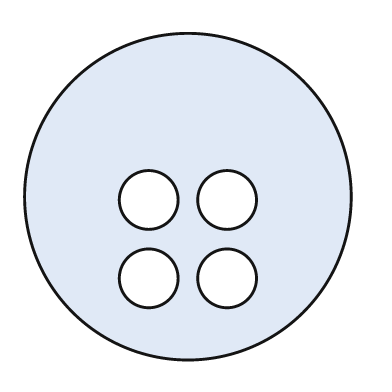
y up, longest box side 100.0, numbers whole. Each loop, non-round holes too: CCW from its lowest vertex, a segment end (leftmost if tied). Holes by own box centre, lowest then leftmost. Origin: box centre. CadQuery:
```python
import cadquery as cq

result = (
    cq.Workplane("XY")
    .moveTo(0.0, 0.0)
    .circle(50.0)
    .moveTo(-12.0, -25.0)
    .circle(9.0)
    .moveTo(12.0, -25.0)
    .circle(9.0)
    .moveTo(-12.0, -1.0)
    .circle(9.0)
    .moveTo(12.0, -1.0)
    .circle(9.0)
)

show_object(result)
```